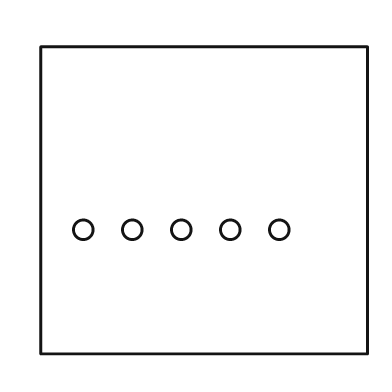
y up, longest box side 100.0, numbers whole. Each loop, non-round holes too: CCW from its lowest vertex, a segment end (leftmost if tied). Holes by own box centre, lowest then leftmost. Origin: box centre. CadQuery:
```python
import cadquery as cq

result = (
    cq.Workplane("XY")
    .moveTo(-50.0, -47.0)
    .lineTo(50.0, -47.0)
    .lineTo(50.0, 47.0)
    .lineTo(-50.0, 47.0)
    .close()
    .moveTo(-37.0, -9.0)
    .circle(3.0)
    .moveTo(-22.0, -9.0)
    .circle(3.0)
    .moveTo(-7.0, -9.0)
    .circle(3.0)
    .moveTo(8.0, -9.0)
    .circle(3.0)
    .moveTo(23.0, -9.0)
    .circle(3.0)
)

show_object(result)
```